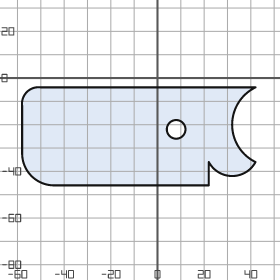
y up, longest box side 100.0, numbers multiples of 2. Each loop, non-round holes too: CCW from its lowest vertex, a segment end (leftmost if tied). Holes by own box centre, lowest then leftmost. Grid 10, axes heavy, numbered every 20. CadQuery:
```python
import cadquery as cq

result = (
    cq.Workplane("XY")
    .moveTo(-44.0, -46.0)
    .lineTo(22.0, -46.0)
    .lineTo(22.0, -36.0)
    .threePointArc((32.0, -42.0), (42.0, -36.0))
    .threePointArc((32.0, -20.0), (42.0, -4.0))
    .lineTo(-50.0, -4.0)
    .threePointArc((-56.0, -6.0), (-58.0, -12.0))
    .lineTo(-58.0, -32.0)
    .threePointArc((-54.0, -42.0), (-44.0, -46.0))
    .close()
    .moveTo(8.0, -22.0)
    .circle(4.0)
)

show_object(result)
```